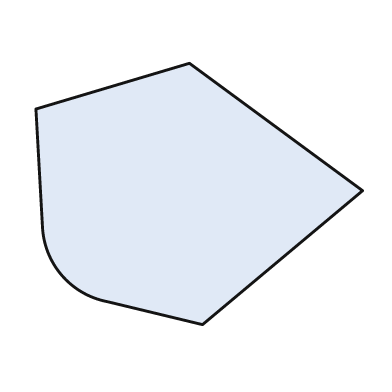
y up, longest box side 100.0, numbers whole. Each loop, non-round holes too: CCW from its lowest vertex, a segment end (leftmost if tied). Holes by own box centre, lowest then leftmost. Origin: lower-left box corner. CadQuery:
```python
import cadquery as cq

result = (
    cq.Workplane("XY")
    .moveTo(51.0, 0.0)
    .lineTo(100.0, 41.0)
    .lineTo(47.0, 80.0)
    .lineTo(0.0, 66.0)
    .lineTo(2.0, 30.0)
    .threePointArc((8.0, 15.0), (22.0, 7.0))
    .close()
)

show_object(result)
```